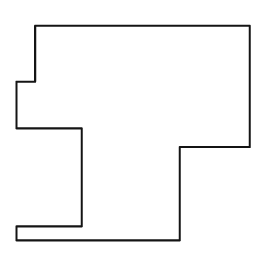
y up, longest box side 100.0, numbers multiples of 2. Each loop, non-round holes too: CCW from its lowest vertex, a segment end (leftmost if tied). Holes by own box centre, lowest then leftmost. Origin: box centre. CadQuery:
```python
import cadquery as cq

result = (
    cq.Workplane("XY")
    .moveTo(-50.0, -46.0)
    .lineTo(20.0, -46.0)
    .lineTo(20.0, -6.0)
    .lineTo(50.0, -6.0)
    .lineTo(50.0, 46.0)
    .lineTo(-42.0, 46.0)
    .lineTo(-42.0, 22.0)
    .lineTo(-50.0, 22.0)
    .lineTo(-50.0, 2.0)
    .lineTo(-22.0, 2.0)
    .lineTo(-22.0, -40.0)
    .lineTo(-50.0, -40.0)
    .close()
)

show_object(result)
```